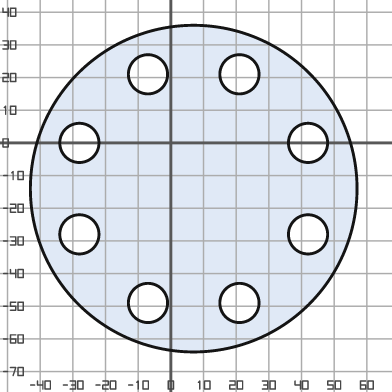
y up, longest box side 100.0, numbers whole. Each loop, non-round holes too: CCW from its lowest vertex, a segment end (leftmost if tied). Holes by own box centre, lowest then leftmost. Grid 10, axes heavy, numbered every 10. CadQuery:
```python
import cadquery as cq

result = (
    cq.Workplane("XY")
    .moveTo(7.0, -14.0)
    .circle(50.0)
    .moveTo(-7.0, -49.0)
    .circle(6.0)
    .moveTo(21.0, -49.0)
    .circle(6.0)
    .moveTo(-28.0, -28.0)
    .circle(6.0)
    .moveTo(42.0, -28.0)
    .circle(6.0)
    .moveTo(-28.0, 0.0)
    .circle(6.0)
    .moveTo(42.0, 0.0)
    .circle(6.0)
    .moveTo(-7.0, 21.0)
    .circle(6.0)
    .moveTo(21.0, 21.0)
    .circle(6.0)
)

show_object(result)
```